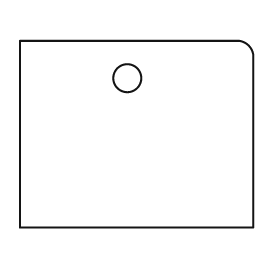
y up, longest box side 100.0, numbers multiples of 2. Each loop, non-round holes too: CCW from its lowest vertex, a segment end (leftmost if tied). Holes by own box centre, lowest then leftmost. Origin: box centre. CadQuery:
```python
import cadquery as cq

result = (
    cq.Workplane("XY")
    .moveTo(-50.0, -40.0)
    .lineTo(50.0, -40.0)
    .lineTo(50.0, 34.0)
    .threePointArc((48.0, 38.0), (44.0, 40.0))
    .lineTo(-50.0, 40.0)
    .close()
    .moveTo(-4.0, 24.0)
    .circle(6.0)
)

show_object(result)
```